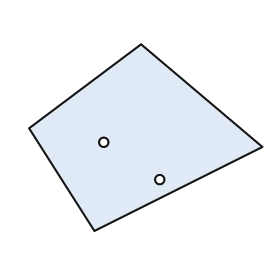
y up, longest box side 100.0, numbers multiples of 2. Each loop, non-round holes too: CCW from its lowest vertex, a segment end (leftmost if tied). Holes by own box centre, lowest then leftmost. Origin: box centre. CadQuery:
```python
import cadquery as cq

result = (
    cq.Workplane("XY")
    .moveTo(-22.0, -40.0)
    .lineTo(50.0, -4.0)
    .lineTo(-2.0, 40.0)
    .lineTo(-50.0, 4.0)
    .close()
    .moveTo(6.0, -18.0)
    .circle(2.0)
    .moveTo(-18.0, -2.0)
    .circle(2.0)
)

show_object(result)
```